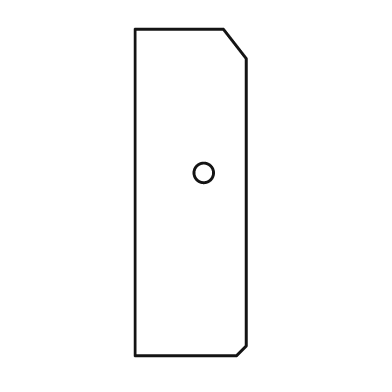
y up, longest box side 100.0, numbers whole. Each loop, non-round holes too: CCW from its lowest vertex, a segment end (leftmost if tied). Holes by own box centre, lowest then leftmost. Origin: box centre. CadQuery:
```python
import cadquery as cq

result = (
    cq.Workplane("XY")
    .moveTo(-17.0, -50.0)
    .lineTo(14.0, -50.0)
    .lineTo(17.0, -47.0)
    .lineTo(17.0, 41.0)
    .lineTo(10.0, 50.0)
    .lineTo(-17.0, 50.0)
    .close()
    .moveTo(4.0, 6.0)
    .circle(3.0)
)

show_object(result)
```